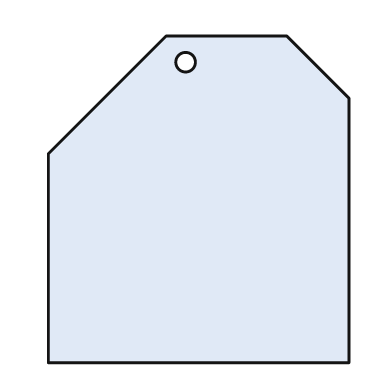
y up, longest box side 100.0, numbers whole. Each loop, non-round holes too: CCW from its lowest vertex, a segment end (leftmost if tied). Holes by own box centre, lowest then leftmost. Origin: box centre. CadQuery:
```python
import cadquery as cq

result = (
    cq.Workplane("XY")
    .moveTo(-46.0, -50.0)
    .lineTo(46.0, -50.0)
    .lineTo(46.0, 31.0)
    .lineTo(27.0, 50.0)
    .lineTo(-10.0, 50.0)
    .lineTo(-46.0, 14.0)
    .close()
    .moveTo(-4.0, 42.0)
    .circle(3.0)
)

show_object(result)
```